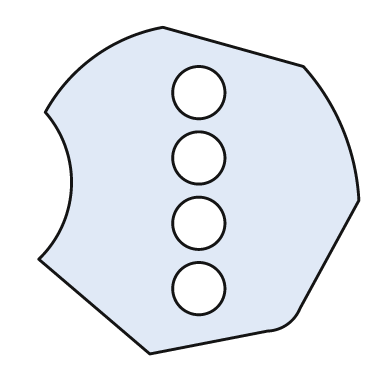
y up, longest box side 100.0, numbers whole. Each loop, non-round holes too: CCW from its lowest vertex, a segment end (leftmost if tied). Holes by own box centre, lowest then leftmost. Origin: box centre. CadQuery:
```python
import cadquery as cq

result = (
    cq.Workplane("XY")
    .moveTo(-15.0, -50.0)
    .lineTo(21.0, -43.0)
    .threePointArc((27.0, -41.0), (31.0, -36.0))
    .lineTo(49.0, -3.0)
    .threePointArc((44.0, 19.0), (32.0, 38.0))
    .lineTo(-11.0, 50.0)
    .threePointArc((-32.0, 41.0), (-47.0, 24.0))
    .threePointArc((-39.0, 1.0), (-49.0, -21.0))
    .close()
    .moveTo(0.0, -30.0)
    .circle(8.0)
    .moveTo(0.0, -10.0)
    .circle(8.0)
    .moveTo(0.0, 10.0)
    .circle(8.0)
    .moveTo(0.0, 30.0)
    .circle(8.0)
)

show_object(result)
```